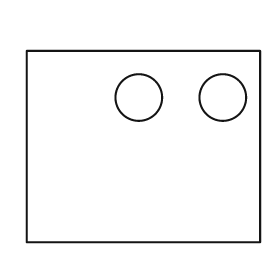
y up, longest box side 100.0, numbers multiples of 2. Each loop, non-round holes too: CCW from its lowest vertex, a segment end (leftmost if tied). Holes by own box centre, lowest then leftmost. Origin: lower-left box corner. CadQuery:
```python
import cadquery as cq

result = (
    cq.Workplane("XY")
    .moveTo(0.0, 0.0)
    .lineTo(100.0, 0.0)
    .lineTo(100.0, 82.0)
    .lineTo(0.0, 82.0)
    .close()
    .moveTo(48.0, 62.0)
    .circle(10.0)
    .moveTo(84.0, 62.0)
    .circle(10.0)
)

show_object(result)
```